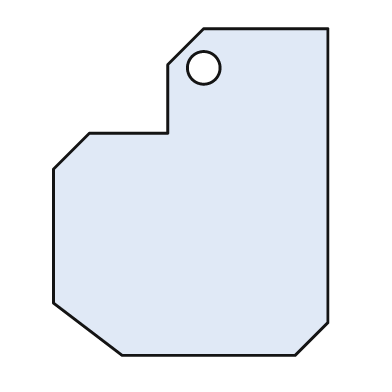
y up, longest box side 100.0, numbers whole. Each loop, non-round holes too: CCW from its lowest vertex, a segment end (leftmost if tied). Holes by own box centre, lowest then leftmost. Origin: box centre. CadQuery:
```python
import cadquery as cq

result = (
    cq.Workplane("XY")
    .moveTo(-21.0, -50.0)
    .lineTo(32.0, -50.0)
    .lineTo(42.0, -40.0)
    .lineTo(42.0, 50.0)
    .lineTo(4.0, 50.0)
    .lineTo(-7.0, 39.0)
    .lineTo(-7.0, 18.0)
    .lineTo(-31.0, 18.0)
    .lineTo(-42.0, 7.0)
    .lineTo(-42.0, -34.0)
    .close()
    .moveTo(4.0, 38.0)
    .circle(5.0)
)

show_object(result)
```